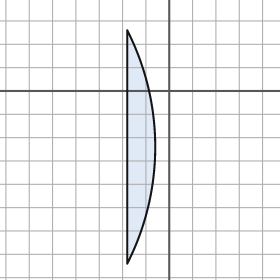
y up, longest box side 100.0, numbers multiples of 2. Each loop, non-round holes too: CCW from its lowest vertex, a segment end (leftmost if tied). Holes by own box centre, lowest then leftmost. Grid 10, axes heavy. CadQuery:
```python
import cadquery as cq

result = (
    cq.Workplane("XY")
    .moveTo(-18.0, -74.0)
    .threePointArc((-6.0, -24.0), (-18.0, 26.0))
    .close()
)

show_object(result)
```